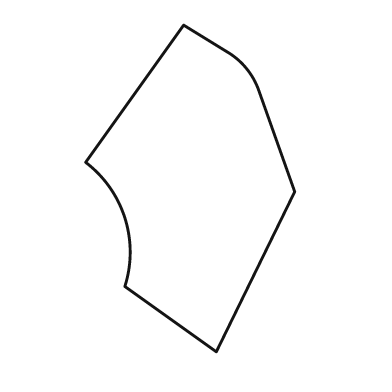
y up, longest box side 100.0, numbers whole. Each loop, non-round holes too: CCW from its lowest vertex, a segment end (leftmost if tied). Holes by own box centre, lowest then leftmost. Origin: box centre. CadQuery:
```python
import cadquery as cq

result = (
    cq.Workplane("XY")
    .moveTo(8.0, -50.0)
    .lineTo(32.0, -1.0)
    .lineTo(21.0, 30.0)
    .threePointArc((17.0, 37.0), (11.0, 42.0))
    .lineTo(-2.0, 50.0)
    .lineTo(-32.0, 8.0)
    .threePointArc((-20.0, -9.0), (-20.0, -30.0))
    .close()
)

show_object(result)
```